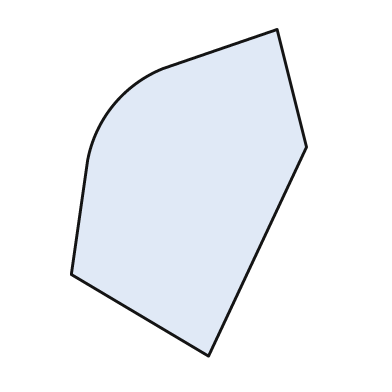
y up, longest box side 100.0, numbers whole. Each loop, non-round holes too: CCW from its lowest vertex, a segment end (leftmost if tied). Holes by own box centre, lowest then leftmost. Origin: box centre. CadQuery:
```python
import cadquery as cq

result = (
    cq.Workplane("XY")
    .moveTo(6.0, -50.0)
    .lineTo(36.0, 14.0)
    .lineTo(27.0, 50.0)
    .lineTo(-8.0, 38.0)
    .threePointArc((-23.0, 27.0), (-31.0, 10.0))
    .lineTo(-36.0, -25.0)
    .close()
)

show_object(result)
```